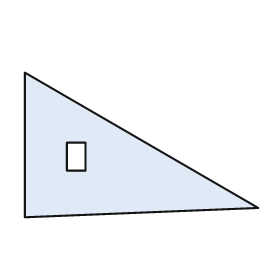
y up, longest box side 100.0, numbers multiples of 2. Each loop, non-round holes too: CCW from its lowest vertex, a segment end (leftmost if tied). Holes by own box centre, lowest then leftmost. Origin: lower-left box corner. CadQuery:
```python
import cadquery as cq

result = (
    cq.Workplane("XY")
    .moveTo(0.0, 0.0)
    .lineTo(100.0, 4.0)
    .lineTo(0.0, 62.0)
    .close()
    .moveTo(18.0, 20.0)
    .lineTo(26.0, 20.0)
    .lineTo(26.0, 32.0)
    .lineTo(18.0, 32.0)
    .close()
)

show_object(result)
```